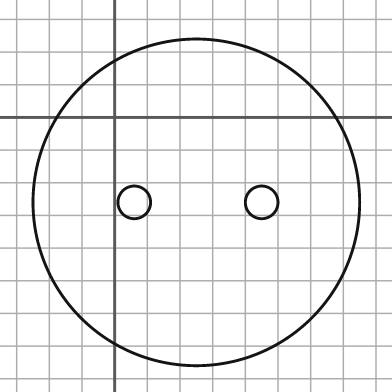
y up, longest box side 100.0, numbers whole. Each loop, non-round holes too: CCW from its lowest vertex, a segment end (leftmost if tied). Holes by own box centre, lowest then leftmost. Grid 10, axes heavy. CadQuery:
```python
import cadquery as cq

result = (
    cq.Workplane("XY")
    .moveTo(25.0, -26.0)
    .circle(50.0)
    .moveTo(6.0, -26.0)
    .circle(5.0)
    .moveTo(45.0, -26.0)
    .circle(5.0)
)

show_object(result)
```